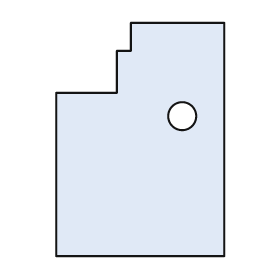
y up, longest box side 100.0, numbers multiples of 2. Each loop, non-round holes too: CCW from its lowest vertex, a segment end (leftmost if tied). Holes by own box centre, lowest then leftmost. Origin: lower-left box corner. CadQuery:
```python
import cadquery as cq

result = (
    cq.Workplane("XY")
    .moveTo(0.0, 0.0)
    .lineTo(72.0, 0.0)
    .lineTo(72.0, 100.0)
    .lineTo(32.0, 100.0)
    .lineTo(32.0, 88.0)
    .lineTo(26.0, 88.0)
    .lineTo(26.0, 70.0)
    .lineTo(0.0, 70.0)
    .close()
    .moveTo(54.0, 60.0)
    .circle(6.0)
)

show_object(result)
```